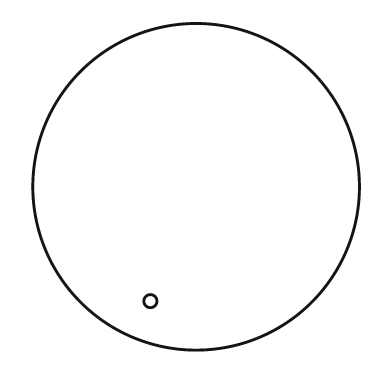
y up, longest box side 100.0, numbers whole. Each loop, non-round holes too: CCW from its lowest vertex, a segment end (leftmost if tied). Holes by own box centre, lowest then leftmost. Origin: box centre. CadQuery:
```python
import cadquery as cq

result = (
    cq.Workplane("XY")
    .moveTo(0.0, 0.0)
    .circle(50.0)
    .moveTo(-14.0, -35.0)
    .circle(2.0)
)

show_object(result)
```